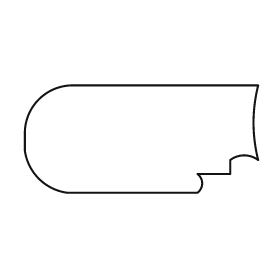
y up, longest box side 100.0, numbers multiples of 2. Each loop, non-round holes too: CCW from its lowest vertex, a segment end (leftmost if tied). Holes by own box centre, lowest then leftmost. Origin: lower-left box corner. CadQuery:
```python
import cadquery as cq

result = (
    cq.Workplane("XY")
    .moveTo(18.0, 0.0)
    .lineTo(74.0, 0.0)
    .threePointArc((76.0, 4.0), (74.0, 8.0))
    .lineTo(88.0, 8.0)
    .lineTo(88.0, 14.0)
    .threePointArc((94.0, 16.0), (100.0, 14.0))
    .threePointArc((98.0, 30.0), (100.0, 46.0))
    .lineTo(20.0, 46.0)
    .threePointArc((6.0, 40.0), (0.0, 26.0))
    .lineTo(0.0, 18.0)
    .threePointArc((6.0, 6.0), (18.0, 0.0))
    .close()
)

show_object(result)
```